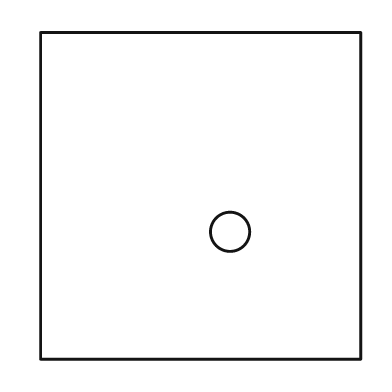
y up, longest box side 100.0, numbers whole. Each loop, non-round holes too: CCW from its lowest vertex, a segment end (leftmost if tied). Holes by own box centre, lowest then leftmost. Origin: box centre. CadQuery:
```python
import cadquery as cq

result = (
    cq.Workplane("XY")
    .moveTo(-49.0, -50.0)
    .lineTo(49.0, -50.0)
    .lineTo(49.0, 50.0)
    .lineTo(-49.0, 50.0)
    .close()
    .moveTo(9.0, -11.0)
    .circle(6.0)
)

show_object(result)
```